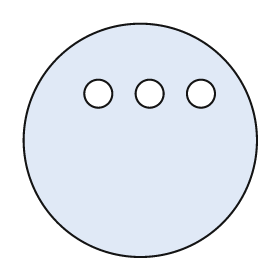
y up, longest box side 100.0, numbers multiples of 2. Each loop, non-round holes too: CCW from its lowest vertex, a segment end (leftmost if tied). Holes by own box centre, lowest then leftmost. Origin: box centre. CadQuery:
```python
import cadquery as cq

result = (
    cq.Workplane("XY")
    .moveTo(0.0, 0.0)
    .circle(50.0)
    .moveTo(-18.0, 20.0)
    .circle(6.0)
    .moveTo(4.0, 20.0)
    .circle(6.0)
    .moveTo(26.0, 20.0)
    .circle(6.0)
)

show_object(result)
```